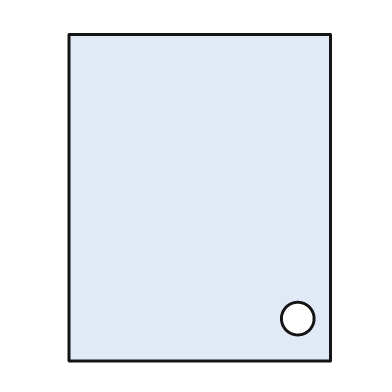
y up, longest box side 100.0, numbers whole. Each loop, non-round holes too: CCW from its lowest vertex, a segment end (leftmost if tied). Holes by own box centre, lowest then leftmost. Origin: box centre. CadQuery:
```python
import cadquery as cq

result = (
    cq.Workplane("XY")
    .moveTo(-40.0, -50.0)
    .lineTo(40.0, -50.0)
    .lineTo(40.0, 50.0)
    .lineTo(-40.0, 50.0)
    .close()
    .moveTo(30.0, -37.0)
    .circle(5.0)
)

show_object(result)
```